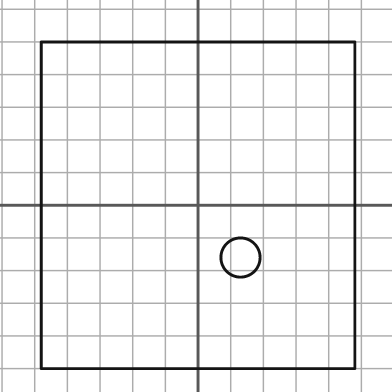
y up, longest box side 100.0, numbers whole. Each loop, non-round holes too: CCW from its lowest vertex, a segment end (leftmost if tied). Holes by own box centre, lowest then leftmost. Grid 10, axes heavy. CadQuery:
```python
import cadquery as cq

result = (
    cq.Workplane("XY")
    .moveTo(-48.0, -50.0)
    .lineTo(48.0, -50.0)
    .lineTo(48.0, 50.0)
    .lineTo(-48.0, 50.0)
    .close()
    .moveTo(13.0, -16.0)
    .circle(6.0)
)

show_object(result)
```